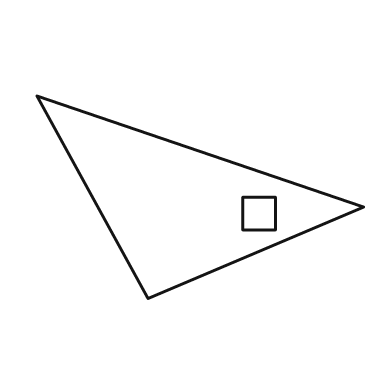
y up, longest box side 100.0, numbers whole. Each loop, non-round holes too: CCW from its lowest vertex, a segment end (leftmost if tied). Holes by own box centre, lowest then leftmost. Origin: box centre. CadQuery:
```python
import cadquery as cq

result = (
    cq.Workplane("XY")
    .moveTo(-16.0, -31.0)
    .lineTo(50.0, -3.0)
    .lineTo(-50.0, 31.0)
    .close()
    .moveTo(13.0, -10.0)
    .lineTo(23.0, -10.0)
    .lineTo(23.0, 0.0)
    .lineTo(13.0, 0.0)
    .close()
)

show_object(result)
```